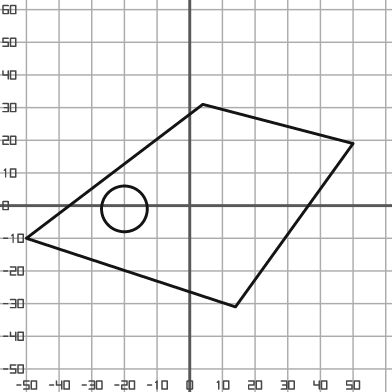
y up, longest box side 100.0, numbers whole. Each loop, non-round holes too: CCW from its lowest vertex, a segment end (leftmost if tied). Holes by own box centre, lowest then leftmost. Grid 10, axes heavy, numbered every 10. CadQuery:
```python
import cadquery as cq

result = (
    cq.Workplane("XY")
    .moveTo(14.0, -31.0)
    .lineTo(50.0, 19.0)
    .lineTo(4.0, 31.0)
    .lineTo(-50.0, -10.0)
    .close()
    .moveTo(-20.0, -1.0)
    .circle(7.0)
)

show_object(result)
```